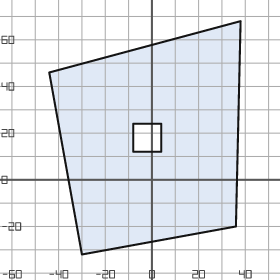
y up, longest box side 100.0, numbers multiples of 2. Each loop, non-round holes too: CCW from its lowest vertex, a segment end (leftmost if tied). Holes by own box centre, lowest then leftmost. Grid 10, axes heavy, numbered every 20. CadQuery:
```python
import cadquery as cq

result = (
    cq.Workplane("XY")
    .moveTo(-30.0, -32.0)
    .lineTo(36.0, -20.0)
    .lineTo(38.0, 68.0)
    .lineTo(-44.0, 46.0)
    .close()
    .moveTo(-8.0, 12.0)
    .lineTo(4.0, 12.0)
    .lineTo(4.0, 24.0)
    .lineTo(-8.0, 24.0)
    .close()
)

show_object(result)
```